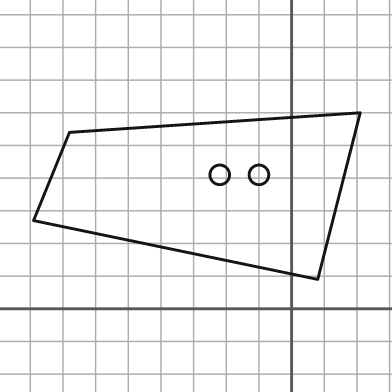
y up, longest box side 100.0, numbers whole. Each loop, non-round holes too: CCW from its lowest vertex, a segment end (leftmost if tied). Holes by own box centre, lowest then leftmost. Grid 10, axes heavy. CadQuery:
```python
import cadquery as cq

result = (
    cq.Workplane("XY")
    .moveTo(8.0, 9.0)
    .lineTo(21.0, 60.0)
    .lineTo(-68.0, 54.0)
    .lineTo(-79.0, 27.0)
    .close()
    .moveTo(-22.0, 41.0)
    .circle(3.0)
    .moveTo(-10.0, 41.0)
    .circle(3.0)
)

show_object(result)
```